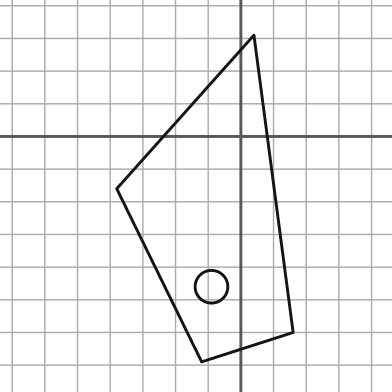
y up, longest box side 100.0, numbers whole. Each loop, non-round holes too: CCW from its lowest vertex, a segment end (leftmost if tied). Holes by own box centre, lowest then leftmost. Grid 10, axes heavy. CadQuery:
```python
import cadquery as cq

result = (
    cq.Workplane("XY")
    .moveTo(-12.0, -69.0)
    .lineTo(16.0, -60.0)
    .lineTo(4.0, 31.0)
    .lineTo(-38.0, -16.0)
    .close()
    .moveTo(-9.0, -46.0)
    .circle(5.0)
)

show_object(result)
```